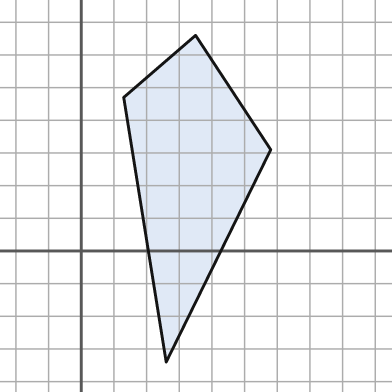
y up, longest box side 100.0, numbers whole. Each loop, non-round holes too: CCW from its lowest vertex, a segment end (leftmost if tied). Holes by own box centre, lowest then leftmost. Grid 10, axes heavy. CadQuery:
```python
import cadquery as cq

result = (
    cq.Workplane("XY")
    .moveTo(26.0, -34.0)
    .lineTo(58.0, 31.0)
    .lineTo(35.0, 66.0)
    .lineTo(13.0, 47.0)
    .close()
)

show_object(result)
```